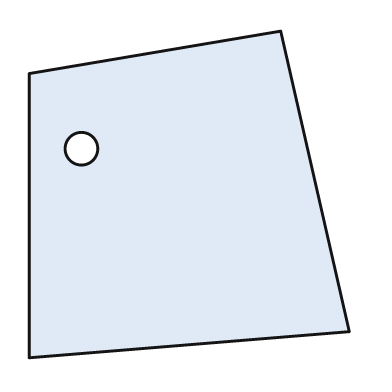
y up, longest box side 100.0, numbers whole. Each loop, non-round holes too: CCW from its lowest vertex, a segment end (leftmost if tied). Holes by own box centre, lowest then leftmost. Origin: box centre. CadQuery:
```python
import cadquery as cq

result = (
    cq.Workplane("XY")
    .moveTo(-49.0, -50.0)
    .lineTo(49.0, -42.0)
    .lineTo(28.0, 50.0)
    .lineTo(-49.0, 37.0)
    .close()
    .moveTo(-33.0, 14.0)
    .circle(5.0)
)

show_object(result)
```